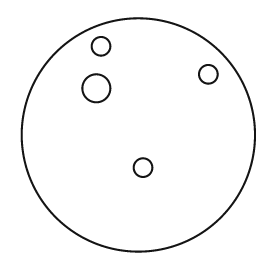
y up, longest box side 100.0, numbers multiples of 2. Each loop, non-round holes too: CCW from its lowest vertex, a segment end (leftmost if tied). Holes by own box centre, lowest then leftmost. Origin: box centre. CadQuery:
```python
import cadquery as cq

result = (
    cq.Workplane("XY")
    .moveTo(0.0, 0.0)
    .circle(50.0)
    .moveTo(2.0, -14.0)
    .circle(4.0)
    .moveTo(-18.0, 20.0)
    .circle(6.0)
    .moveTo(30.0, 26.0)
    .circle(4.0)
    .moveTo(-16.0, 38.0)
    .circle(4.0)
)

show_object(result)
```